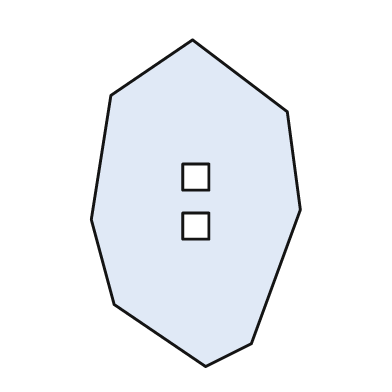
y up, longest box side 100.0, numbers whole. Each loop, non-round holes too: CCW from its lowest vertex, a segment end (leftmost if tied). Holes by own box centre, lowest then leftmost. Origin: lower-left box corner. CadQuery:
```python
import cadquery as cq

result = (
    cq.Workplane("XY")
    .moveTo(35.0, 0.0)
    .lineTo(49.0, 7.0)
    .lineTo(64.0, 48.0)
    .lineTo(60.0, 78.0)
    .lineTo(31.0, 100.0)
    .lineTo(6.0, 83.0)
    .lineTo(0.0, 45.0)
    .lineTo(7.0, 19.0)
    .close()
    .moveTo(28.0, 39.0)
    .lineTo(36.0, 39.0)
    .lineTo(36.0, 47.0)
    .lineTo(28.0, 47.0)
    .close()
    .moveTo(28.0, 54.0)
    .lineTo(36.0, 54.0)
    .lineTo(36.0, 62.0)
    .lineTo(28.0, 62.0)
    .close()
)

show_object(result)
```